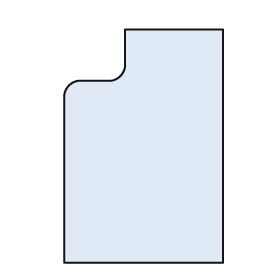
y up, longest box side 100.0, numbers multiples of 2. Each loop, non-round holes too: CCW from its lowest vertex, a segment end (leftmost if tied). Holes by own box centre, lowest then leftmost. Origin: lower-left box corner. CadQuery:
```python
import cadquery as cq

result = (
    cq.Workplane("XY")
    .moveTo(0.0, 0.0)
    .lineTo(68.0, 0.0)
    .lineTo(68.0, 100.0)
    .lineTo(26.0, 100.0)
    .lineTo(26.0, 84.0)
    .threePointArc((24.0, 80.0), (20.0, 78.0))
    .lineTo(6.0, 78.0)
    .threePointArc((2.0, 76.0), (0.0, 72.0))
    .close()
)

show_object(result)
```